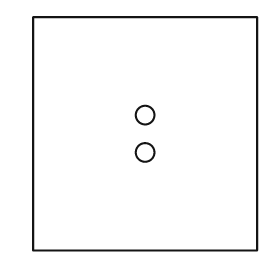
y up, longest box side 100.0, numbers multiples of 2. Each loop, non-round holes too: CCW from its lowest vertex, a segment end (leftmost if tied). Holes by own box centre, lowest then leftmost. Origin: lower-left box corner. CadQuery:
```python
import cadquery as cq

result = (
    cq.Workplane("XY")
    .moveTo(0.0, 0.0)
    .lineTo(96.0, 0.0)
    .lineTo(96.0, 100.0)
    .lineTo(0.0, 100.0)
    .close()
    .moveTo(48.0, 42.0)
    .circle(4.0)
    .moveTo(48.0, 58.0)
    .circle(4.0)
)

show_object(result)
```